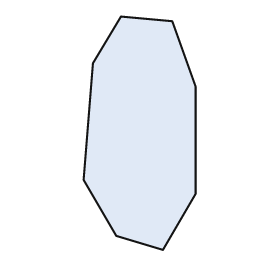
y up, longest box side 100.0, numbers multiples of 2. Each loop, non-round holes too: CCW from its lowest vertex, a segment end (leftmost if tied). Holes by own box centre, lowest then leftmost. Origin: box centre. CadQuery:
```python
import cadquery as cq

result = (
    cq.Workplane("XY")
    .moveTo(10.0, -50.0)
    .lineTo(24.0, -26.0)
    .lineTo(24.0, 20.0)
    .lineTo(14.0, 48.0)
    .lineTo(-8.0, 50.0)
    .lineTo(-20.0, 30.0)
    .lineTo(-24.0, -20.0)
    .lineTo(-10.0, -44.0)
    .close()
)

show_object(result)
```